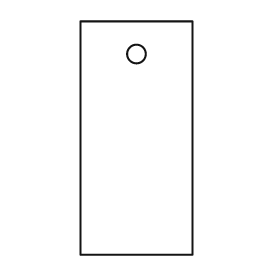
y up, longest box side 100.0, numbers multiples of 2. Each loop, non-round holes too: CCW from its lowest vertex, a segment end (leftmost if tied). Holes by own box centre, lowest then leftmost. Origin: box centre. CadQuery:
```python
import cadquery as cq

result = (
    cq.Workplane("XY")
    .moveTo(-24.0, -50.0)
    .lineTo(24.0, -50.0)
    .lineTo(24.0, 50.0)
    .lineTo(-24.0, 50.0)
    .close()
    .moveTo(0.0, 36.0)
    .circle(4.0)
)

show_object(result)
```